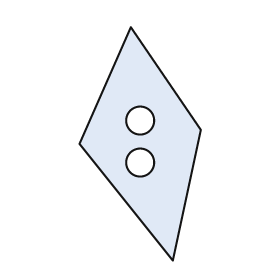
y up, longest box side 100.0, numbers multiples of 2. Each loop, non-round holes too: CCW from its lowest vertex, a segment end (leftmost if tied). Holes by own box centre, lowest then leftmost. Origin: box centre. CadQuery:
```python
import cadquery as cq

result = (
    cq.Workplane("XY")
    .moveTo(14.0, -50.0)
    .lineTo(26.0, 6.0)
    .lineTo(-4.0, 50.0)
    .lineTo(-26.0, 0.0)
    .close()
    .moveTo(0.0, -8.0)
    .circle(6.0)
    .moveTo(0.0, 10.0)
    .circle(6.0)
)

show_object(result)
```